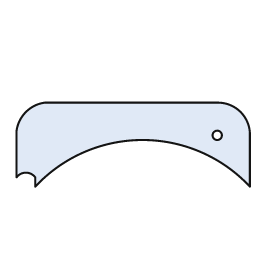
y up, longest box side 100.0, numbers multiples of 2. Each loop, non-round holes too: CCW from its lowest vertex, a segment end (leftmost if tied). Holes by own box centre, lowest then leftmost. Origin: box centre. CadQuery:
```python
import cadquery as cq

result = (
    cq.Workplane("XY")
    .moveTo(-42.0, -18.0)
    .threePointArc((4.0, 2.0), (50.0, -18.0))
    .lineTo(50.0, 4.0)
    .threePointArc((46.0, 14.0), (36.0, 18.0))
    .lineTo(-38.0, 18.0)
    .threePointArc((-46.0, 14.0), (-50.0, 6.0))
    .lineTo(-50.0, -14.0)
    .threePointArc((-46.0, -12.0), (-42.0, -14.0))
    .close()
    .moveTo(36.0, 4.0)
    .circle(2.0)
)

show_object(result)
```